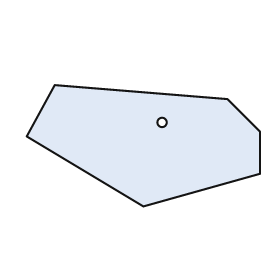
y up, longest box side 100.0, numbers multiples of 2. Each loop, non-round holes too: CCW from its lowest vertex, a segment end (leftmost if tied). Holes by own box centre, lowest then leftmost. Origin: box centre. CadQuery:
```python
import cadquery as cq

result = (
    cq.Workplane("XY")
    .moveTo(0.0, -26.0)
    .lineTo(50.0, -12.0)
    .lineTo(50.0, 6.0)
    .lineTo(36.0, 20.0)
    .lineTo(-38.0, 26.0)
    .lineTo(-50.0, 4.0)
    .close()
    .moveTo(8.0, 10.0)
    .circle(2.0)
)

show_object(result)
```